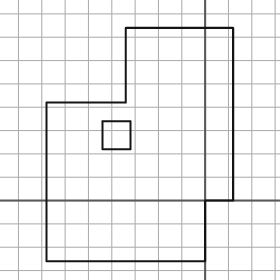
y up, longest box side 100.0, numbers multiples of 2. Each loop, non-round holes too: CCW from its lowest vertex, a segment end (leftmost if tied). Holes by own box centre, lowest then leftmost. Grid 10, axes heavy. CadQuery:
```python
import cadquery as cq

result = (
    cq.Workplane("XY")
    .moveTo(-68.0, -26.0)
    .lineTo(0.0, -26.0)
    .lineTo(0.0, 0.0)
    .lineTo(12.0, 0.0)
    .lineTo(12.0, 74.0)
    .lineTo(-34.0, 74.0)
    .lineTo(-34.0, 42.0)
    .lineTo(-68.0, 42.0)
    .close()
    .moveTo(-44.0, 22.0)
    .lineTo(-32.0, 22.0)
    .lineTo(-32.0, 34.0)
    .lineTo(-44.0, 34.0)
    .close()
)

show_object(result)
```